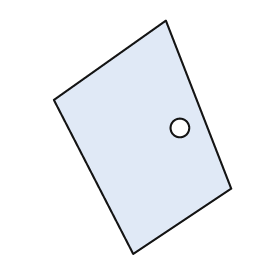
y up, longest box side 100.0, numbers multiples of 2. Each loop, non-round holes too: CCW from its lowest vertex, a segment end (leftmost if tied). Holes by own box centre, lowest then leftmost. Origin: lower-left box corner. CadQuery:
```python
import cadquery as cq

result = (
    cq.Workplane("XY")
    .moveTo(34.0, 0.0)
    .lineTo(76.0, 28.0)
    .lineTo(48.0, 100.0)
    .lineTo(0.0, 66.0)
    .close()
    .moveTo(54.0, 54.0)
    .circle(4.0)
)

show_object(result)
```